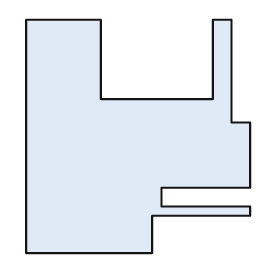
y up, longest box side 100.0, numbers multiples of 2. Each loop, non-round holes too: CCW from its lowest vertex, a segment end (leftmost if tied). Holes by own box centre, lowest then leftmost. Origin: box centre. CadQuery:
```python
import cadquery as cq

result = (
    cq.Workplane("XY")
    .moveTo(-48.0, -50.0)
    .lineTo(6.0, -50.0)
    .lineTo(6.0, -34.0)
    .lineTo(48.0, -34.0)
    .lineTo(48.0, -30.0)
    .lineTo(10.0, -30.0)
    .lineTo(10.0, -22.0)
    .lineTo(48.0, -22.0)
    .lineTo(48.0, 6.0)
    .lineTo(40.0, 6.0)
    .lineTo(40.0, 50.0)
    .lineTo(32.0, 50.0)
    .lineTo(32.0, 16.0)
    .lineTo(-16.0, 16.0)
    .lineTo(-16.0, 50.0)
    .lineTo(-48.0, 50.0)
    .close()
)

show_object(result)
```